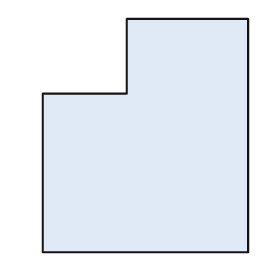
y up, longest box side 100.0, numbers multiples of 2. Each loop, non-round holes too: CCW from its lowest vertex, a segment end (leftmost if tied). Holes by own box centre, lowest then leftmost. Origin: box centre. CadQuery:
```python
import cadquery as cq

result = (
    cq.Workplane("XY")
    .moveTo(-44.0, -50.0)
    .lineTo(44.0, -50.0)
    .lineTo(44.0, 50.0)
    .lineTo(-8.0, 50.0)
    .lineTo(-8.0, 18.0)
    .lineTo(-44.0, 18.0)
    .close()
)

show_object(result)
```